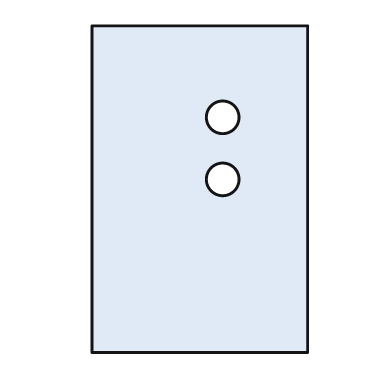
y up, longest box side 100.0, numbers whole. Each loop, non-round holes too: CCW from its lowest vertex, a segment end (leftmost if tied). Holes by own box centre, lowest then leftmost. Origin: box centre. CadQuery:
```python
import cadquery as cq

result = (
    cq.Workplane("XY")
    .moveTo(-33.0, -50.0)
    .lineTo(33.0, -50.0)
    .lineTo(33.0, 50.0)
    .lineTo(-33.0, 50.0)
    .close()
    .moveTo(7.0, 3.0)
    .circle(5.0)
    .moveTo(7.0, 22.0)
    .circle(5.0)
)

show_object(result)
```